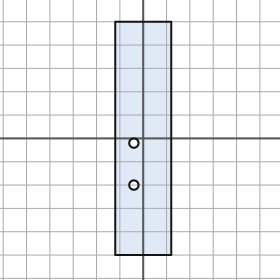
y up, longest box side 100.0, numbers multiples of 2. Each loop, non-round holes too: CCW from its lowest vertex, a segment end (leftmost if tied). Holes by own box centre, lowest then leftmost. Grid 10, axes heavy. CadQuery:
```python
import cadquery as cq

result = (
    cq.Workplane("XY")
    .moveTo(-12.0, -50.0)
    .lineTo(12.0, -50.0)
    .lineTo(12.0, 50.0)
    .lineTo(-12.0, 50.0)
    .close()
    .moveTo(-4.0, -20.0)
    .circle(2.0)
    .moveTo(-4.0, -2.0)
    .circle(2.0)
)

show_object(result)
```